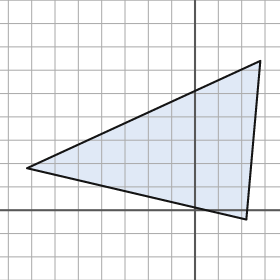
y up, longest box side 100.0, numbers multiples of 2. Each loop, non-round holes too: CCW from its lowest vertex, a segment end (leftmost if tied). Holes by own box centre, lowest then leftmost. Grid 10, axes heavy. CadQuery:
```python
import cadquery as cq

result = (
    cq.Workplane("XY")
    .moveTo(22.0, -4.0)
    .lineTo(28.0, 64.0)
    .lineTo(-72.0, 18.0)
    .close()
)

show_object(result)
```